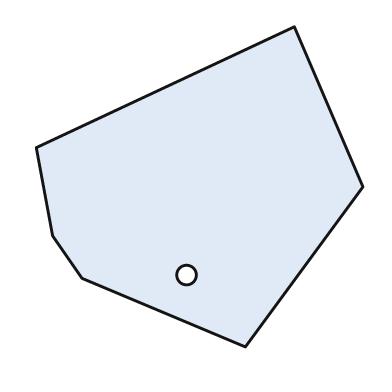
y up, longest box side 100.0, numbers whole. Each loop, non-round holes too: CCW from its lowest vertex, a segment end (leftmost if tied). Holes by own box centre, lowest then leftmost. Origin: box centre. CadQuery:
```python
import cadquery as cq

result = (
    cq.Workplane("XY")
    .moveTo(14.0, -49.0)
    .lineTo(50.0, 0.0)
    .lineTo(29.0, 49.0)
    .lineTo(-50.0, 12.0)
    .lineTo(-45.0, -15.0)
    .lineTo(-36.0, -28.0)
    .close()
    .moveTo(-4.0, -27.0)
    .circle(3.0)
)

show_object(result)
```